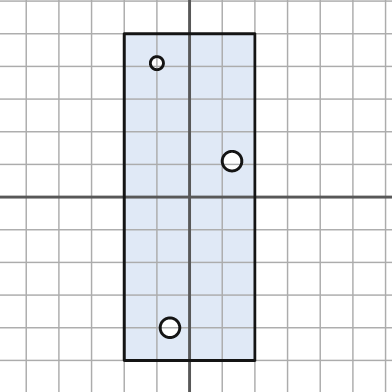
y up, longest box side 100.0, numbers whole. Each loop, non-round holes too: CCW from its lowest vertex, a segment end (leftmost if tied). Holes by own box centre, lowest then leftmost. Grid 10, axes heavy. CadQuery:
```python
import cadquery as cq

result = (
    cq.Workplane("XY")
    .moveTo(-20.0, -50.0)
    .lineTo(20.0, -50.0)
    .lineTo(20.0, 50.0)
    .lineTo(-20.0, 50.0)
    .close()
    .moveTo(-6.0, -40.0)
    .circle(3.0)
    .moveTo(13.0, 11.0)
    .circle(3.0)
    .moveTo(-10.0, 41.0)
    .circle(2.0)
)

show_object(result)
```